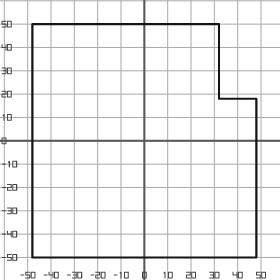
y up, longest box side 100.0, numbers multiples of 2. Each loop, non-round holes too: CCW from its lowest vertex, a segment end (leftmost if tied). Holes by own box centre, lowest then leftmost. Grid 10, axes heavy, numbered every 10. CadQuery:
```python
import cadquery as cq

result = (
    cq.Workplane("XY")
    .moveTo(-48.0, -50.0)
    .lineTo(48.0, -50.0)
    .lineTo(48.0, 18.0)
    .lineTo(32.0, 18.0)
    .lineTo(32.0, 50.0)
    .lineTo(-48.0, 50.0)
    .close()
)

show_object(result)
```